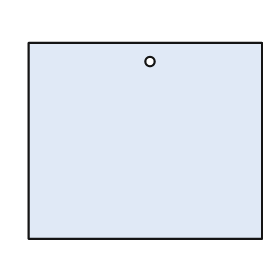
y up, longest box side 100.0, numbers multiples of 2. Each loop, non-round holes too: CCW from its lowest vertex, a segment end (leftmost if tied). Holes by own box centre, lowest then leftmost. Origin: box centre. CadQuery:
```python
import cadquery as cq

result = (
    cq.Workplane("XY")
    .moveTo(-50.0, -42.0)
    .lineTo(50.0, -42.0)
    .lineTo(50.0, 42.0)
    .lineTo(-50.0, 42.0)
    .close()
    .moveTo(2.0, 34.0)
    .circle(2.0)
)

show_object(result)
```